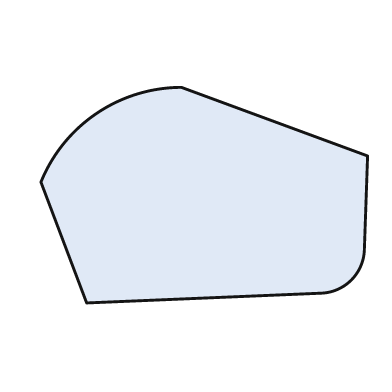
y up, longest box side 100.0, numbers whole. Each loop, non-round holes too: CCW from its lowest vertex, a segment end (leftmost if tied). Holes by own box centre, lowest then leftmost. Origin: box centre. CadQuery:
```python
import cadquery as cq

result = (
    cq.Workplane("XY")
    .moveTo(-36.0, -33.0)
    .lineTo(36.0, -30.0)
    .threePointArc((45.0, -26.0), (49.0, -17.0))
    .lineTo(50.0, 12.0)
    .lineTo(-7.0, 33.0)
    .threePointArc((-33.0, 25.0), (-50.0, 4.0))
    .close()
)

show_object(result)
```